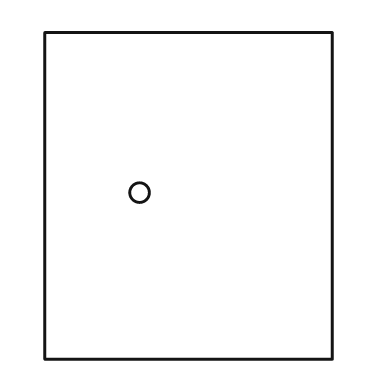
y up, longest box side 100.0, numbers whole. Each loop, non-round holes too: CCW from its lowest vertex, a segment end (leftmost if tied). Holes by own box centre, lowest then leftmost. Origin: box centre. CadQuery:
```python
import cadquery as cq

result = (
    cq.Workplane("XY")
    .moveTo(-44.0, -50.0)
    .lineTo(44.0, -50.0)
    .lineTo(44.0, 50.0)
    .lineTo(-44.0, 50.0)
    .close()
    .moveTo(-15.0, 1.0)
    .circle(3.0)
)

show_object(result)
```